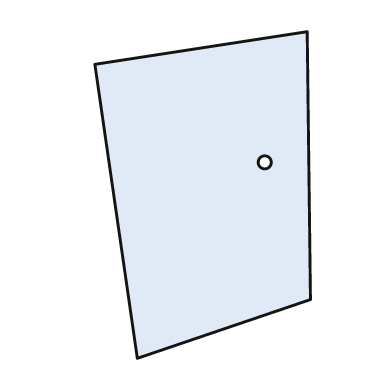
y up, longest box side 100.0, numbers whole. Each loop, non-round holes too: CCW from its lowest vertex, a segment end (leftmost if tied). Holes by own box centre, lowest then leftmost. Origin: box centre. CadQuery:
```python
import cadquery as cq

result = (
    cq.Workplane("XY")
    .moveTo(-20.0, -50.0)
    .lineTo(33.0, -32.0)
    .lineTo(32.0, 50.0)
    .lineTo(-33.0, 40.0)
    .close()
    .moveTo(19.0, 10.0)
    .circle(2.0)
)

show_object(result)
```